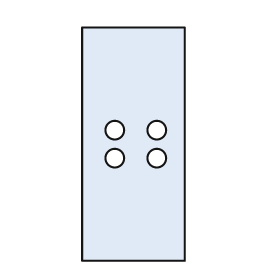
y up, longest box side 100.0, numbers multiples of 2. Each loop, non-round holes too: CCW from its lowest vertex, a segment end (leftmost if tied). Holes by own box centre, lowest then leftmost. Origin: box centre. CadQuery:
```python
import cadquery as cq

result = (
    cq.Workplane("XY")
    .moveTo(-22.0, -50.0)
    .lineTo(22.0, -50.0)
    .lineTo(22.0, 50.0)
    .lineTo(-22.0, 50.0)
    .close()
    .moveTo(-8.0, -6.0)
    .circle(4.0)
    .moveTo(10.0, -6.0)
    .circle(4.0)
    .moveTo(-8.0, 6.0)
    .circle(4.0)
    .moveTo(10.0, 6.0)
    .circle(4.0)
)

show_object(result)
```